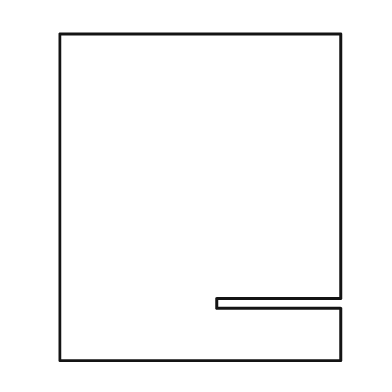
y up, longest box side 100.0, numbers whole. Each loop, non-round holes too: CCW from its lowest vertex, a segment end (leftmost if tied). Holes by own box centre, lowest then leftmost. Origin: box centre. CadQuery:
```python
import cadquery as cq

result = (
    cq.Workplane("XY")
    .moveTo(-43.0, -50.0)
    .lineTo(43.0, -50.0)
    .lineTo(43.0, -34.0)
    .lineTo(5.0, -34.0)
    .lineTo(5.0, -31.0)
    .lineTo(43.0, -31.0)
    .lineTo(43.0, 50.0)
    .lineTo(-43.0, 50.0)
    .close()
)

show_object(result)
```